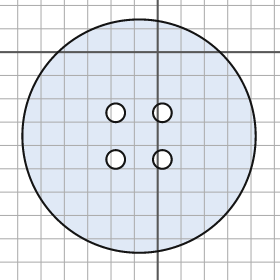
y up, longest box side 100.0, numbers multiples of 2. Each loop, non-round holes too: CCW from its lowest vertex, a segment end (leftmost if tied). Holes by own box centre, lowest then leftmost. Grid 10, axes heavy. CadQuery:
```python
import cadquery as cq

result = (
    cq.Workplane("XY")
    .moveTo(-8.0, -36.0)
    .circle(50.0)
    .moveTo(-18.0, -46.0)
    .circle(4.0)
    .moveTo(2.0, -46.0)
    .circle(4.0)
    .moveTo(-18.0, -26.0)
    .circle(4.0)
    .moveTo(2.0, -26.0)
    .circle(4.0)
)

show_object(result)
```